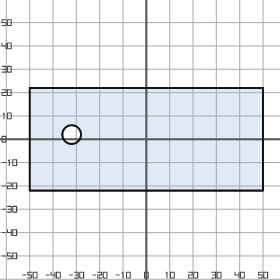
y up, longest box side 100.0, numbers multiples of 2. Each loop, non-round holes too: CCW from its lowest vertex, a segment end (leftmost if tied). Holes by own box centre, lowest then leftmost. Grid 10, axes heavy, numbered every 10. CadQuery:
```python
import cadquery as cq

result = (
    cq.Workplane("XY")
    .moveTo(-50.0, -22.0)
    .lineTo(50.0, -22.0)
    .lineTo(50.0, 22.0)
    .lineTo(-50.0, 22.0)
    .close()
    .moveTo(-32.0, 2.0)
    .circle(4.0)
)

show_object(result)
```